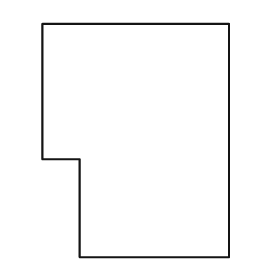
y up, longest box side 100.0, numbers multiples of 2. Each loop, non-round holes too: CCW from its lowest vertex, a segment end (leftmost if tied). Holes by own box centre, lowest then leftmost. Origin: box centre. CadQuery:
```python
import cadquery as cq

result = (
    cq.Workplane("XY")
    .moveTo(-24.0, -50.0)
    .lineTo(40.0, -50.0)
    .lineTo(40.0, 50.0)
    .lineTo(-40.0, 50.0)
    .lineTo(-40.0, -8.0)
    .lineTo(-24.0, -8.0)
    .close()
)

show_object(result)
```